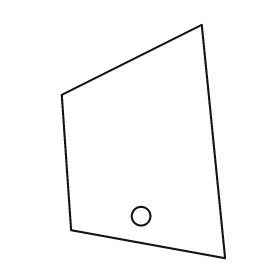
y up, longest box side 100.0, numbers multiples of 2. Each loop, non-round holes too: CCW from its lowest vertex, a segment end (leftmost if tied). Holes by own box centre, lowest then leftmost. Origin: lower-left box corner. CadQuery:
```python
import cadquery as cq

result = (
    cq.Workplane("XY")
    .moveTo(70.0, 0.0)
    .lineTo(60.0, 100.0)
    .lineTo(0.0, 70.0)
    .lineTo(4.0, 12.0)
    .close()
    .moveTo(34.0, 18.0)
    .circle(4.0)
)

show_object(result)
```